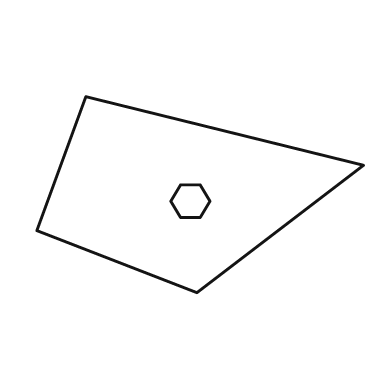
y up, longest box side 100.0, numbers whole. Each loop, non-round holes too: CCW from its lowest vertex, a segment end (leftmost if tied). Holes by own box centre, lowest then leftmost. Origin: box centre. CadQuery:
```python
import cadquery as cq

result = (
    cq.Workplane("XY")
    .moveTo(-1.0, -30.0)
    .lineTo(50.0, 9.0)
    .lineTo(-35.0, 30.0)
    .lineTo(-50.0, -11.0)
    .close()
    .moveTo(-6.0, -7.0)
    .lineTo(0.0, -7.0)
    .lineTo(3.0, -2.0)
    .lineTo(0.0, 3.0)
    .lineTo(-6.0, 3.0)
    .lineTo(-9.0, -2.0)
    .close()
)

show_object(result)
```